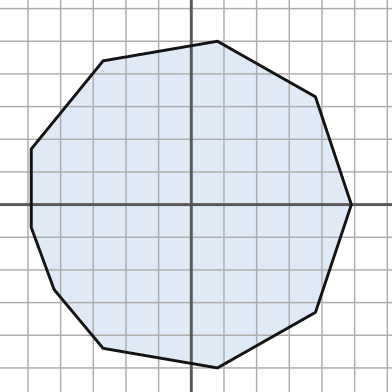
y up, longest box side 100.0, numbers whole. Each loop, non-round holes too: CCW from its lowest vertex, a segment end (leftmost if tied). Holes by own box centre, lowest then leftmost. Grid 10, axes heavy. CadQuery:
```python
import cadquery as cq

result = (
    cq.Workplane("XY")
    .moveTo(8.0, -50.0)
    .lineTo(38.0, -33.0)
    .lineTo(49.0, 0.0)
    .lineTo(38.0, 33.0)
    .lineTo(8.0, 50.0)
    .lineTo(-27.0, 44.0)
    .lineTo(-49.0, 17.0)
    .lineTo(-49.0, -7.0)
    .lineTo(-42.0, -26.0)
    .lineTo(-27.0, -44.0)
    .close()
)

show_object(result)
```